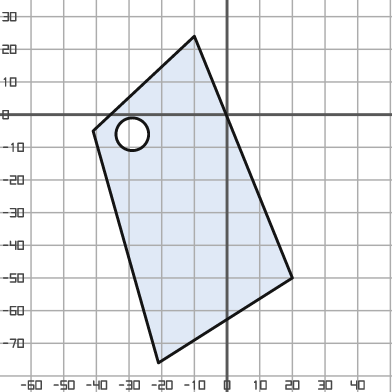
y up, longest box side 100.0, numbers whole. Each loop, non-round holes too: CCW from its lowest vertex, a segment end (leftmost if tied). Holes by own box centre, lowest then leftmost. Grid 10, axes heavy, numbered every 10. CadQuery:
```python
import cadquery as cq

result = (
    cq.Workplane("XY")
    .moveTo(-21.0, -76.0)
    .lineTo(20.0, -50.0)
    .lineTo(-10.0, 24.0)
    .lineTo(-41.0, -5.0)
    .close()
    .moveTo(-29.0, -6.0)
    .circle(5.0)
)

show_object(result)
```